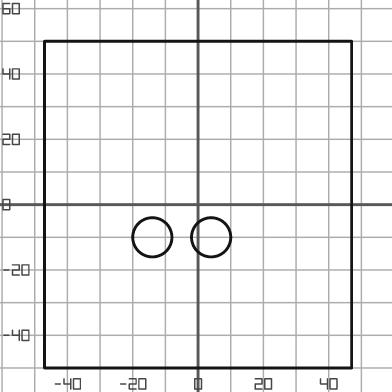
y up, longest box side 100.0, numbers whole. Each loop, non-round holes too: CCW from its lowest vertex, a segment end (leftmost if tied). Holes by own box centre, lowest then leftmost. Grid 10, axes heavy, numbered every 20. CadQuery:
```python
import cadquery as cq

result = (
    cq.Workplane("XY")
    .moveTo(-47.0, -50.0)
    .lineTo(47.0, -50.0)
    .lineTo(47.0, 50.0)
    .lineTo(-47.0, 50.0)
    .close()
    .moveTo(-14.0, -10.0)
    .circle(6.0)
    .moveTo(4.0, -10.0)
    .circle(6.0)
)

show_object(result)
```